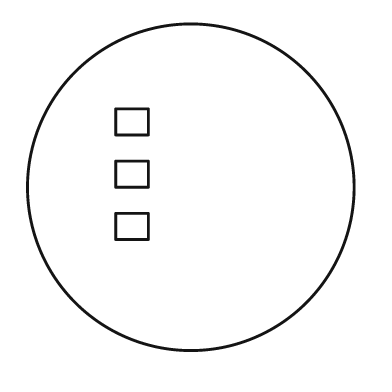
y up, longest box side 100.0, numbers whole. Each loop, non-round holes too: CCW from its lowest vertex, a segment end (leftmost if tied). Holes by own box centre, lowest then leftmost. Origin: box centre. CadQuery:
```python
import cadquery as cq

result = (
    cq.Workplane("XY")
    .moveTo(0.0, 0.0)
    .circle(50.0)
    .moveTo(-23.0, -16.0)
    .lineTo(-13.0, -16.0)
    .lineTo(-13.0, -8.0)
    .lineTo(-23.0, -8.0)
    .close()
    .moveTo(-23.0, 0.0)
    .lineTo(-13.0, 0.0)
    .lineTo(-13.0, 8.0)
    .lineTo(-23.0, 8.0)
    .close()
    .moveTo(-23.0, 16.0)
    .lineTo(-13.0, 16.0)
    .lineTo(-13.0, 24.0)
    .lineTo(-23.0, 24.0)
    .close()
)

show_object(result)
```